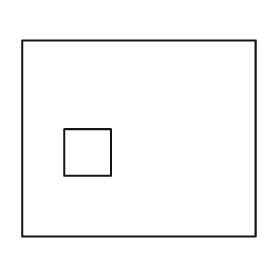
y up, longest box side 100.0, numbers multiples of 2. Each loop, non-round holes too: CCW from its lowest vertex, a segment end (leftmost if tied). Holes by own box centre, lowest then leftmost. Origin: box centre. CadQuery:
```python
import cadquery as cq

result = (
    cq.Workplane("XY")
    .moveTo(-50.0, -42.0)
    .lineTo(50.0, -42.0)
    .lineTo(50.0, 42.0)
    .lineTo(-50.0, 42.0)
    .close()
    .moveTo(-32.0, -16.0)
    .lineTo(-12.0, -16.0)
    .lineTo(-12.0, 4.0)
    .lineTo(-32.0, 4.0)
    .close()
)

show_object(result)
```